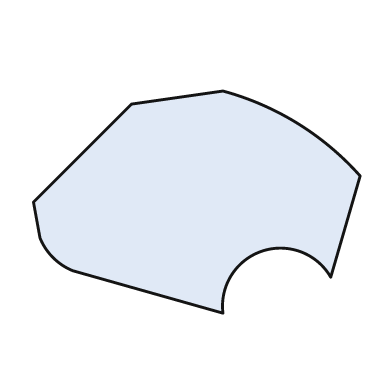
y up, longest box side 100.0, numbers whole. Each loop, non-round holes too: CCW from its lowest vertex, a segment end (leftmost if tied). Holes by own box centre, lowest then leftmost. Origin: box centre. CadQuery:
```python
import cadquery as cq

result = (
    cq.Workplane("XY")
    .moveTo(8.0, -34.0)
    .threePointArc((20.0, -15.0), (41.0, -23.0))
    .lineTo(50.0, 8.0)
    .threePointArc((31.0, 24.0), (8.0, 34.0))
    .lineTo(-20.0, 30.0)
    .lineTo(-50.0, 0.0)
    .lineTo(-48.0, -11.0)
    .threePointArc((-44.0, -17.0), (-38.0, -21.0))
    .close()
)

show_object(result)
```